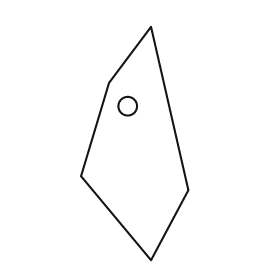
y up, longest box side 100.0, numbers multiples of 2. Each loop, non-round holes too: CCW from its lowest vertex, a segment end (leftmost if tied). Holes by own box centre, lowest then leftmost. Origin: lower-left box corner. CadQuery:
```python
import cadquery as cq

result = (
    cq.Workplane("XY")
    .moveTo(30.0, 0.0)
    .lineTo(46.0, 30.0)
    .lineTo(30.0, 100.0)
    .lineTo(12.0, 76.0)
    .lineTo(0.0, 36.0)
    .close()
    .moveTo(20.0, 66.0)
    .circle(4.0)
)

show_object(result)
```